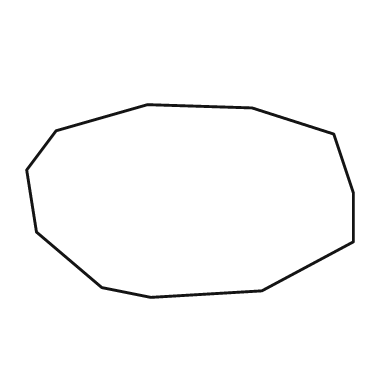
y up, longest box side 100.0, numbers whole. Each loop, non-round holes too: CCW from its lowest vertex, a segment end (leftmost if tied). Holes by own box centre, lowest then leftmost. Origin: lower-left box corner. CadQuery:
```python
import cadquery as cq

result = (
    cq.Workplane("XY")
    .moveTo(38.0, 0.0)
    .lineTo(72.0, 2.0)
    .lineTo(100.0, 17.0)
    .lineTo(100.0, 32.0)
    .lineTo(94.0, 50.0)
    .lineTo(69.0, 58.0)
    .lineTo(37.0, 59.0)
    .lineTo(9.0, 51.0)
    .lineTo(0.0, 39.0)
    .lineTo(3.0, 20.0)
    .lineTo(23.0, 3.0)
    .close()
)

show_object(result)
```